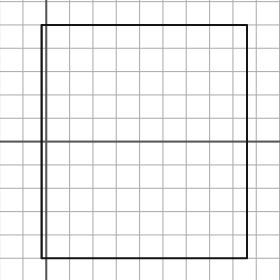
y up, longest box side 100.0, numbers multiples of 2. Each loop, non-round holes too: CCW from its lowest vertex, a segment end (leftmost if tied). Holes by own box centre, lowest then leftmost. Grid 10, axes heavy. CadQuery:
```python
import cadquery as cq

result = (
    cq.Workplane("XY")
    .moveTo(-2.0, -50.0)
    .lineTo(86.0, -50.0)
    .lineTo(86.0, 50.0)
    .lineTo(-2.0, 50.0)
    .close()
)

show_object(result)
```